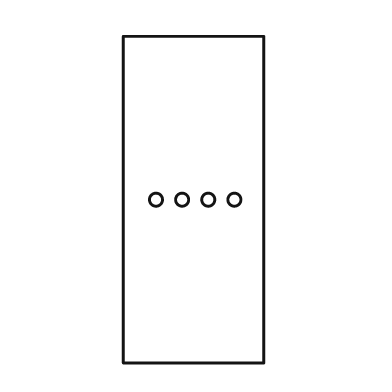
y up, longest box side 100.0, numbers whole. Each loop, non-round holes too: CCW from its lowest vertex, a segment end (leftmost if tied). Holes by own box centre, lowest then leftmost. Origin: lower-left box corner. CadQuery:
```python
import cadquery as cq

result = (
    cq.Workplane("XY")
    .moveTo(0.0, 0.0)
    .lineTo(43.0, 0.0)
    .lineTo(43.0, 100.0)
    .lineTo(0.0, 100.0)
    .close()
    .moveTo(10.0, 50.0)
    .circle(2.0)
    .moveTo(18.0, 50.0)
    .circle(2.0)
    .moveTo(26.0, 50.0)
    .circle(2.0)
    .moveTo(34.0, 50.0)
    .circle(2.0)
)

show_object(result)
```